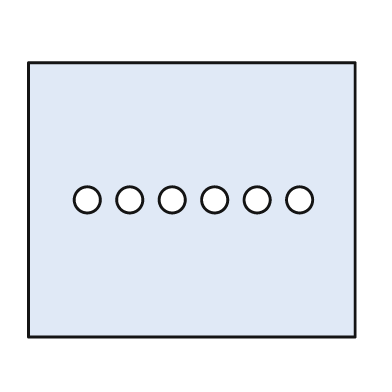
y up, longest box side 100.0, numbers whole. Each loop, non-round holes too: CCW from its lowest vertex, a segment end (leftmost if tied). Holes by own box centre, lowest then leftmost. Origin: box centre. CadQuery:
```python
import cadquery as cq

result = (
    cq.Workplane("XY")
    .moveTo(-50.0, -42.0)
    .lineTo(50.0, -42.0)
    .lineTo(50.0, 42.0)
    .lineTo(-50.0, 42.0)
    .close()
    .moveTo(-32.0, 0.0)
    .circle(4.0)
    .moveTo(-19.0, 0.0)
    .circle(4.0)
    .moveTo(-6.0, 0.0)
    .circle(4.0)
    .moveTo(7.0, 0.0)
    .circle(4.0)
    .moveTo(20.0, 0.0)
    .circle(4.0)
    .moveTo(33.0, 0.0)
    .circle(4.0)
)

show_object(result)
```